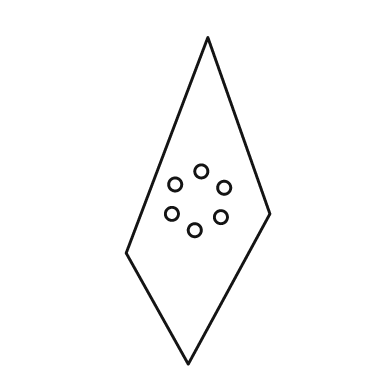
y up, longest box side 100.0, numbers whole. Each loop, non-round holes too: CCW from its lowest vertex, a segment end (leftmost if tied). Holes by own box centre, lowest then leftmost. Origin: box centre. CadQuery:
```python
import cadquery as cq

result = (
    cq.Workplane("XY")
    .moveTo(-3.0, -50.0)
    .lineTo(22.0, -4.0)
    .lineTo(3.0, 50.0)
    .lineTo(-22.0, -16.0)
    .close()
    .moveTo(-1.0, -9.0)
    .circle(2.0)
    .moveTo(7.0, -5.0)
    .circle(2.0)
    .moveTo(-8.0, -4.0)
    .circle(2.0)
    .moveTo(8.0, 4.0)
    .circle(2.0)
    .moveTo(-7.0, 5.0)
    .circle(2.0)
    .moveTo(1.0, 9.0)
    .circle(2.0)
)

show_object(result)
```